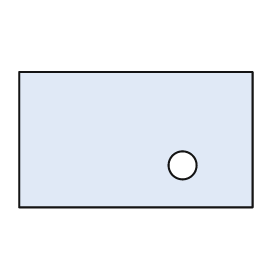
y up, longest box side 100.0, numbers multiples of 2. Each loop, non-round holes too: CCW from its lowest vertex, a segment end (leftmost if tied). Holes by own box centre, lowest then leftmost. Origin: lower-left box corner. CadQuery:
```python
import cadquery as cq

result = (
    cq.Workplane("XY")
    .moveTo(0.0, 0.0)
    .lineTo(100.0, 0.0)
    .lineTo(100.0, 58.0)
    .lineTo(0.0, 58.0)
    .close()
    .moveTo(70.0, 18.0)
    .circle(6.0)
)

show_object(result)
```